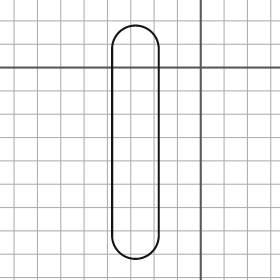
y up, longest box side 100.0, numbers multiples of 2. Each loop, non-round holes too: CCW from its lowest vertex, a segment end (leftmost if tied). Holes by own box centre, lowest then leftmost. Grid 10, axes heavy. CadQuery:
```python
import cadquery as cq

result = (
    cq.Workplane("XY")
    .moveTo(-38.0, -72.0)
    .threePointArc((-28.0, -82.0), (-18.0, -72.0))
    .lineTo(-18.0, 8.0)
    .threePointArc((-28.0, 18.0), (-38.0, 8.0))
    .close()
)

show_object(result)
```